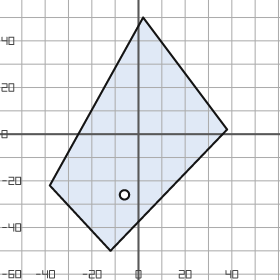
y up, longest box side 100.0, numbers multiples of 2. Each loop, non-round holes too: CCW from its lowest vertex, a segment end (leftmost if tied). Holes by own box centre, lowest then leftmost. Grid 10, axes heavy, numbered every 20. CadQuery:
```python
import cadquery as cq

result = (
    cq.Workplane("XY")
    .moveTo(-12.0, -50.0)
    .lineTo(38.0, 2.0)
    .lineTo(2.0, 50.0)
    .lineTo(-38.0, -22.0)
    .close()
    .moveTo(-6.0, -26.0)
    .circle(2.0)
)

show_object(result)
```